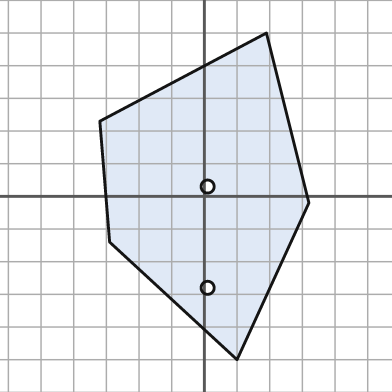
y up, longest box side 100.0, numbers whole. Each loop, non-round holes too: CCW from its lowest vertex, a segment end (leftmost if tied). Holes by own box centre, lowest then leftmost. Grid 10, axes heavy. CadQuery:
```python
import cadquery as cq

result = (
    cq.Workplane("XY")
    .moveTo(10.0, -50.0)
    .lineTo(32.0, -2.0)
    .lineTo(19.0, 50.0)
    .lineTo(-32.0, 23.0)
    .lineTo(-29.0, -14.0)
    .close()
    .moveTo(1.0, -28.0)
    .circle(2.0)
    .moveTo(1.0, 3.0)
    .circle(2.0)
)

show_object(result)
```